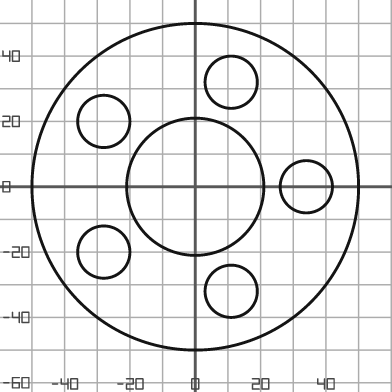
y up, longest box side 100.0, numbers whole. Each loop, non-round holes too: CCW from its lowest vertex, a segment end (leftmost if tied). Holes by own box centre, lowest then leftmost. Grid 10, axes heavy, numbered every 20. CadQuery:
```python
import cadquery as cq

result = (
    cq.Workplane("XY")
    .moveTo(0.0, 0.0)
    .circle(50.0)
    .moveTo(11.0, -32.0)
    .circle(8.0)
    .moveTo(-28.0, -20.0)
    .circle(8.0)
    .moveTo(0.0, 0.0)
    .circle(21.0)
    .moveTo(34.0, 0.0)
    .circle(8.0)
    .moveTo(-28.0, 20.0)
    .circle(8.0)
    .moveTo(11.0, 32.0)
    .circle(8.0)
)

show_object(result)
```